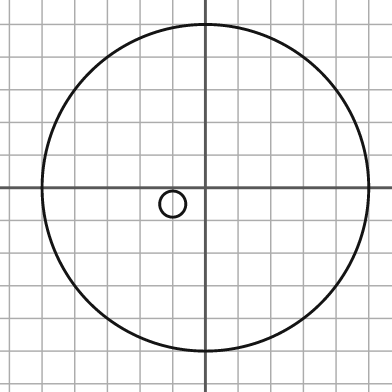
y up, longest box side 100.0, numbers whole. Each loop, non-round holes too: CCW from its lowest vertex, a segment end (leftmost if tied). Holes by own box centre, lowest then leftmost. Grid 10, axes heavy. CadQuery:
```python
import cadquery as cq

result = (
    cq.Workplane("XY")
    .moveTo(0.0, 0.0)
    .circle(50.0)
    .moveTo(-10.0, -5.0)
    .circle(4.0)
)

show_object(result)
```